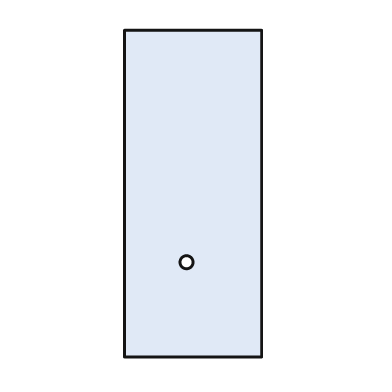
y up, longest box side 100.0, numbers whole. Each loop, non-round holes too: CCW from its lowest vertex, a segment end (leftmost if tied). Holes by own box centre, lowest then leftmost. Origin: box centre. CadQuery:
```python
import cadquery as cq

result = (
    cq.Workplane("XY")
    .moveTo(-21.0, -50.0)
    .lineTo(21.0, -50.0)
    .lineTo(21.0, 50.0)
    .lineTo(-21.0, 50.0)
    .close()
    .moveTo(-2.0, -21.0)
    .circle(2.0)
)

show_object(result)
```